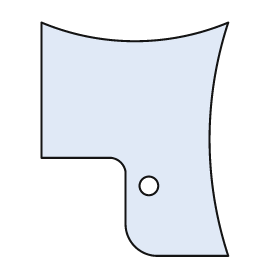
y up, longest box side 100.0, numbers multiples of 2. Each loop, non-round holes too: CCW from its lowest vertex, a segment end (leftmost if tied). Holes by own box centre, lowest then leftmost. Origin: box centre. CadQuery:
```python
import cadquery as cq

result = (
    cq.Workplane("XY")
    .moveTo(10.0, -50.0)
    .lineTo(40.0, -50.0)
    .threePointArc((32.0, 0.0), (40.0, 50.0))
    .threePointArc((0.0, 42.0), (-40.0, 50.0))
    .lineTo(-40.0, -8.0)
    .lineTo(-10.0, -8.0)
    .threePointArc((-6.0, -10.0), (-4.0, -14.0))
    .lineTo(-4.0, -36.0)
    .threePointArc((0.0, -46.0), (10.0, -50.0))
    .close()
    .moveTo(6.0, -20.0)
    .circle(4.0)
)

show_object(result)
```